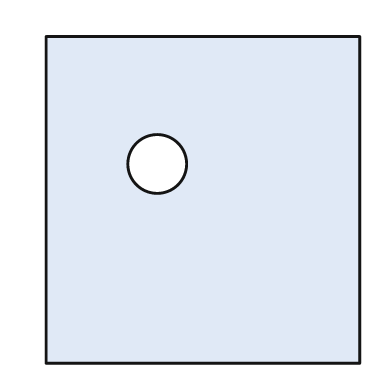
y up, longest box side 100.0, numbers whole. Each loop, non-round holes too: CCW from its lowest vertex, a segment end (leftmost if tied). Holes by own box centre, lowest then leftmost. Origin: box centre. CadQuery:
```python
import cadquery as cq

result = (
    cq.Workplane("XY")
    .moveTo(-48.0, -50.0)
    .lineTo(48.0, -50.0)
    .lineTo(48.0, 50.0)
    .lineTo(-48.0, 50.0)
    .close()
    .moveTo(-14.0, 11.0)
    .circle(9.0)
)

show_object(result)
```